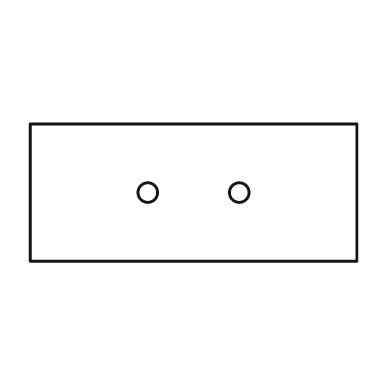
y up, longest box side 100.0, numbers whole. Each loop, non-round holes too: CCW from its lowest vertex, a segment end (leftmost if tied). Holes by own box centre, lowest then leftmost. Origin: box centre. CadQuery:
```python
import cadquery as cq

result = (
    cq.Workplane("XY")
    .moveTo(-50.0, -21.0)
    .lineTo(50.0, -21.0)
    .lineTo(50.0, 21.0)
    .lineTo(-50.0, 21.0)
    .close()
    .moveTo(-14.0, 0.0)
    .circle(3.0)
    .moveTo(14.0, 0.0)
    .circle(3.0)
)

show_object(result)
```